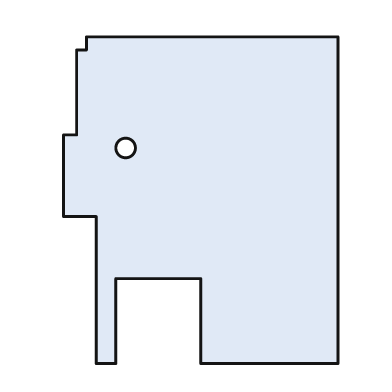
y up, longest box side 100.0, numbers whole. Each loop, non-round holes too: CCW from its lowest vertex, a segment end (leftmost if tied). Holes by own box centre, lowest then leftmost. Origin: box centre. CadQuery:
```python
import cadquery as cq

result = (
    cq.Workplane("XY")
    .moveTo(-32.0, -50.0)
    .lineTo(-26.0, -50.0)
    .lineTo(-26.0, -24.0)
    .lineTo(0.0, -24.0)
    .lineTo(0.0, -50.0)
    .lineTo(42.0, -50.0)
    .lineTo(42.0, 50.0)
    .lineTo(-35.0, 50.0)
    .lineTo(-35.0, 46.0)
    .lineTo(-38.0, 46.0)
    .lineTo(-38.0, 20.0)
    .lineTo(-42.0, 20.0)
    .lineTo(-42.0, -5.0)
    .lineTo(-32.0, -5.0)
    .close()
    .moveTo(-23.0, 16.0)
    .circle(3.0)
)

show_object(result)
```